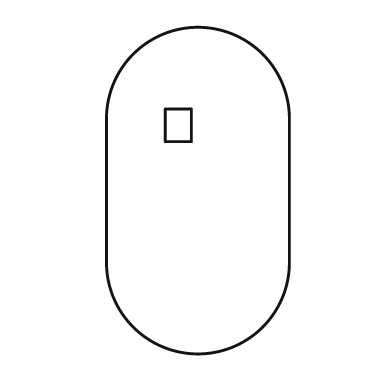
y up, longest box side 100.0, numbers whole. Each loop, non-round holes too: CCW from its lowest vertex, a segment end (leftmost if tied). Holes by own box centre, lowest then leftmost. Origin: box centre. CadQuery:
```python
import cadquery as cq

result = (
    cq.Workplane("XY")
    .moveTo(-28.0, -22.0)
    .threePointArc((0.0, -50.0), (28.0, -22.0))
    .lineTo(28.0, 22.0)
    .threePointArc((0.0, 50.0), (-28.0, 22.0))
    .close()
    .moveTo(-10.0, 15.0)
    .lineTo(-2.0, 15.0)
    .lineTo(-2.0, 25.0)
    .lineTo(-10.0, 25.0)
    .close()
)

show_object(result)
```